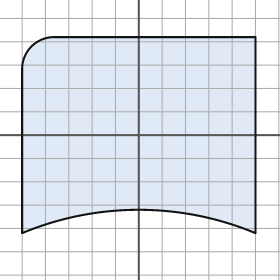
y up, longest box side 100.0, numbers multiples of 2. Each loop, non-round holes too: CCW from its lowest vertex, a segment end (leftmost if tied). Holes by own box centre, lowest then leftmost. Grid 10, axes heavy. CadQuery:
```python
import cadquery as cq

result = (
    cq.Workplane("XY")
    .moveTo(-50.0, -42.0)
    .threePointArc((0.0, -32.0), (50.0, -42.0))
    .lineTo(50.0, 42.0)
    .lineTo(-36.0, 42.0)
    .threePointArc((-46.0, 38.0), (-50.0, 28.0))
    .close()
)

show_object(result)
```